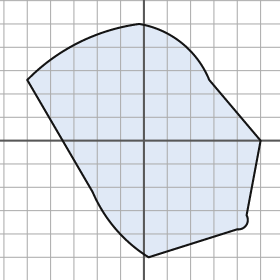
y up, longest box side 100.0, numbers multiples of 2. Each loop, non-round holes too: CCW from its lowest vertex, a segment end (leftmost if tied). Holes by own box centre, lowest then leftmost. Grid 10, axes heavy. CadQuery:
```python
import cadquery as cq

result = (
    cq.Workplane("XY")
    .moveTo(2.0, -50.0)
    .lineTo(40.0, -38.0)
    .threePointArc((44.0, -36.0), (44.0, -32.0))
    .lineTo(50.0, 0.0)
    .lineTo(28.0, 26.0)
    .threePointArc((16.0, 42.0), (-2.0, 50.0))
    .threePointArc((-28.0, 42.0), (-50.0, 26.0))
    .lineTo(-22.0, -22.0)
    .threePointArc((-12.0, -38.0), (2.0, -50.0))
    .close()
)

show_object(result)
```